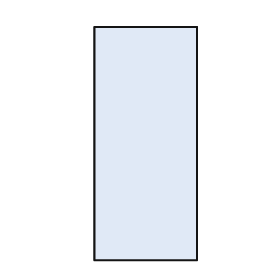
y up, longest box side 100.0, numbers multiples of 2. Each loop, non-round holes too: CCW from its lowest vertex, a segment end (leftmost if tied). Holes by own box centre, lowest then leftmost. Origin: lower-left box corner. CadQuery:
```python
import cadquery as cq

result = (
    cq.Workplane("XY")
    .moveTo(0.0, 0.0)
    .lineTo(44.0, 0.0)
    .lineTo(44.0, 100.0)
    .lineTo(0.0, 100.0)
    .close()
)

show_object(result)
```